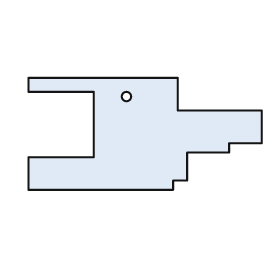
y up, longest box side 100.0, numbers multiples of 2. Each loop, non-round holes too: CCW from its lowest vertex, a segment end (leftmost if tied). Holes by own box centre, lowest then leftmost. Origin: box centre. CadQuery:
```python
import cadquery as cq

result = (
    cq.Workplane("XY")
    .moveTo(-50.0, -24.0)
    .lineTo(12.0, -24.0)
    .lineTo(12.0, -20.0)
    .lineTo(18.0, -20.0)
    .lineTo(18.0, -8.0)
    .lineTo(36.0, -8.0)
    .lineTo(36.0, -4.0)
    .lineTo(50.0, -4.0)
    .lineTo(50.0, 10.0)
    .lineTo(14.0, 10.0)
    .lineTo(14.0, 24.0)
    .lineTo(-50.0, 24.0)
    .lineTo(-50.0, 18.0)
    .lineTo(-22.0, 18.0)
    .lineTo(-22.0, -10.0)
    .lineTo(-50.0, -10.0)
    .close()
    .moveTo(-8.0, 16.0)
    .circle(2.0)
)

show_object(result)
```